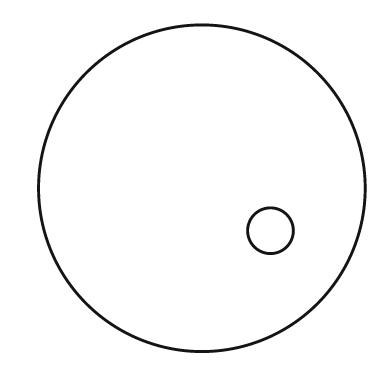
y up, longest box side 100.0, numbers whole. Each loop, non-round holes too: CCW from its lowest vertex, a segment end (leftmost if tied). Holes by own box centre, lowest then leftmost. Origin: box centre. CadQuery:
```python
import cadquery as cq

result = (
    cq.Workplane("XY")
    .moveTo(0.0, 0.0)
    .circle(50.0)
    .moveTo(21.0, -13.0)
    .circle(7.0)
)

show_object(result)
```